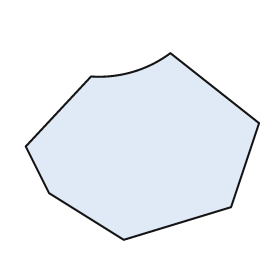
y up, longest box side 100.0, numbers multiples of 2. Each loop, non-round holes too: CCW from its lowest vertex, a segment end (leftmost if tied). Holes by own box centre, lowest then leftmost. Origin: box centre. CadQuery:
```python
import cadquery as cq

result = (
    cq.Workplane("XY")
    .moveTo(-8.0, -40.0)
    .lineTo(38.0, -26.0)
    .lineTo(50.0, 10.0)
    .lineTo(12.0, 40.0)
    .threePointArc((-4.0, 32.0), (-22.0, 30.0))
    .lineTo(-50.0, 0.0)
    .lineTo(-40.0, -20.0)
    .close()
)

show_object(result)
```